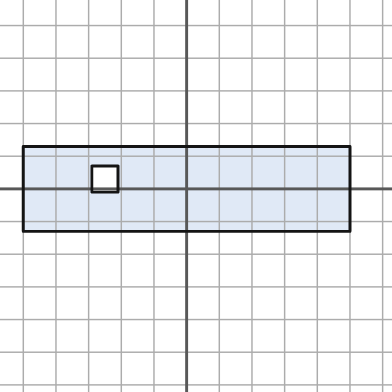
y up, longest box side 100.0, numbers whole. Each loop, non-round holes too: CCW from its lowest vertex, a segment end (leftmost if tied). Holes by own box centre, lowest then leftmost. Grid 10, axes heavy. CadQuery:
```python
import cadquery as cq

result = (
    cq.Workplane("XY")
    .moveTo(-50.0, -13.0)
    .lineTo(50.0, -13.0)
    .lineTo(50.0, 13.0)
    .lineTo(-50.0, 13.0)
    .close()
    .moveTo(-29.0, -1.0)
    .lineTo(-21.0, -1.0)
    .lineTo(-21.0, 7.0)
    .lineTo(-29.0, 7.0)
    .close()
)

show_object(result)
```